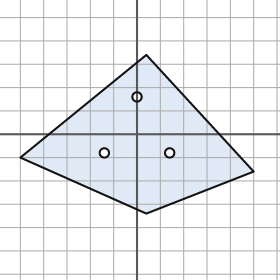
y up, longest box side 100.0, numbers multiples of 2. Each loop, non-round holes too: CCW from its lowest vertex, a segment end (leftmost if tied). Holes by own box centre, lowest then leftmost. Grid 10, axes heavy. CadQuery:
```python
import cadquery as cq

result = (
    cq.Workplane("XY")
    .moveTo(4.0, -34.0)
    .lineTo(50.0, -16.0)
    .lineTo(4.0, 34.0)
    .lineTo(-50.0, -10.0)
    .close()
    .moveTo(-14.0, -8.0)
    .circle(2.0)
    .moveTo(14.0, -8.0)
    .circle(2.0)
    .moveTo(0.0, 16.0)
    .circle(2.0)
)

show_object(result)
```